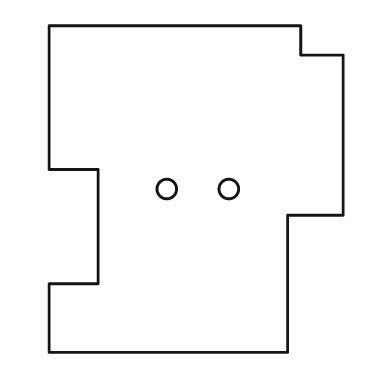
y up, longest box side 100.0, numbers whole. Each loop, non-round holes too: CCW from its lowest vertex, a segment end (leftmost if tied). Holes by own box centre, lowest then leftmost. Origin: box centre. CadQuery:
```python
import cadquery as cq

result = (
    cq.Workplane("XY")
    .moveTo(-45.0, -50.0)
    .lineTo(28.0, -50.0)
    .lineTo(28.0, -8.0)
    .lineTo(45.0, -8.0)
    .lineTo(45.0, 41.0)
    .lineTo(32.0, 41.0)
    .lineTo(32.0, 50.0)
    .lineTo(-45.0, 50.0)
    .lineTo(-45.0, 6.0)
    .lineTo(-30.0, 6.0)
    .lineTo(-30.0, -29.0)
    .lineTo(-45.0, -29.0)
    .close()
    .moveTo(-9.0, 0.0)
    .circle(3.0)
    .moveTo(10.0, 0.0)
    .circle(3.0)
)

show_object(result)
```